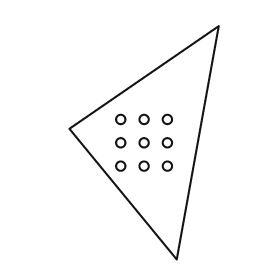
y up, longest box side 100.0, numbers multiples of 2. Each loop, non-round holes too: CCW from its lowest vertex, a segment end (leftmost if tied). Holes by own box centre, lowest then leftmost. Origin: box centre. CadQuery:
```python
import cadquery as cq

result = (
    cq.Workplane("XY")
    .moveTo(14.0, -50.0)
    .lineTo(32.0, 50.0)
    .lineTo(-32.0, 6.0)
    .close()
    .moveTo(-10.0, -10.0)
    .circle(2.0)
    .moveTo(0.0, -10.0)
    .circle(2.0)
    .moveTo(10.0, -10.0)
    .circle(2.0)
    .moveTo(-10.0, 0.0)
    .circle(2.0)
    .moveTo(0.0, 0.0)
    .circle(2.0)
    .moveTo(10.0, 0.0)
    .circle(2.0)
    .moveTo(-10.0, 10.0)
    .circle(2.0)
    .moveTo(0.0, 10.0)
    .circle(2.0)
    .moveTo(10.0, 10.0)
    .circle(2.0)
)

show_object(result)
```